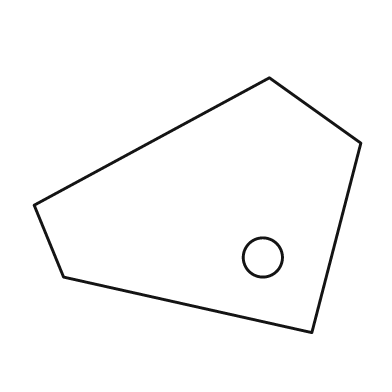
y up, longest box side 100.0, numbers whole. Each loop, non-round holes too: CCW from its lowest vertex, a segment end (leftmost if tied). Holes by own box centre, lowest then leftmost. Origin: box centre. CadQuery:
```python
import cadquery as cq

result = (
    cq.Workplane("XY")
    .moveTo(35.0, -39.0)
    .lineTo(50.0, 19.0)
    .lineTo(22.0, 39.0)
    .lineTo(-50.0, 0.0)
    .lineTo(-41.0, -22.0)
    .close()
    .moveTo(20.0, -16.0)
    .circle(6.0)
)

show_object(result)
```